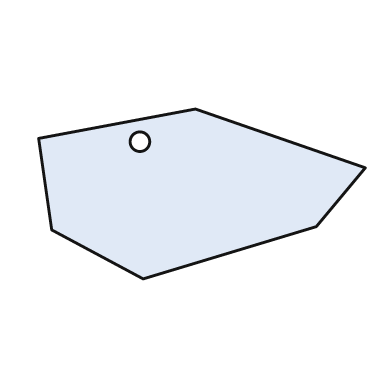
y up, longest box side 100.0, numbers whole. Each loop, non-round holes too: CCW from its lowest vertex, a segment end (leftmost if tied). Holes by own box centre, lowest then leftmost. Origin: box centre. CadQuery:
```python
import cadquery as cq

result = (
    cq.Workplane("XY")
    .moveTo(-18.0, -26.0)
    .lineTo(35.0, -10.0)
    .lineTo(50.0, 8.0)
    .lineTo(-2.0, 26.0)
    .lineTo(-50.0, 17.0)
    .lineTo(-46.0, -11.0)
    .close()
    .moveTo(-19.0, 16.0)
    .circle(3.0)
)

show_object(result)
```